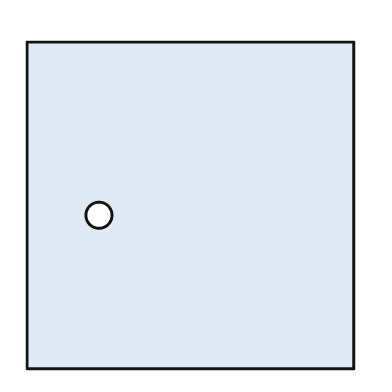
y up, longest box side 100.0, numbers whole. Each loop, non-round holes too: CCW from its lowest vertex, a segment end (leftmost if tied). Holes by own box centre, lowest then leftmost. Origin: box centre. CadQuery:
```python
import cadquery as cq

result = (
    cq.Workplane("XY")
    .moveTo(-50.0, -50.0)
    .lineTo(50.0, -50.0)
    .lineTo(50.0, 50.0)
    .lineTo(-50.0, 50.0)
    .close()
    .moveTo(-28.0, -3.0)
    .circle(4.0)
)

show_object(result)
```